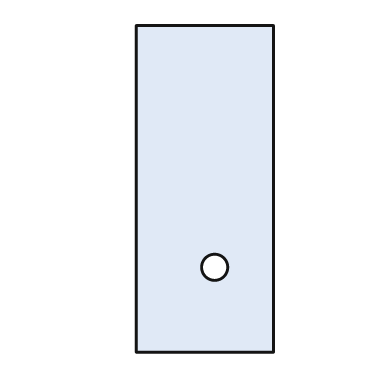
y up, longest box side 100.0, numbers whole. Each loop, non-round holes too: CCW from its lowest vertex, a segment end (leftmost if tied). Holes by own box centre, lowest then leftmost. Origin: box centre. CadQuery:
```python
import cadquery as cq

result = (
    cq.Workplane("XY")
    .moveTo(-21.0, -50.0)
    .lineTo(21.0, -50.0)
    .lineTo(21.0, 50.0)
    .lineTo(-21.0, 50.0)
    .close()
    .moveTo(3.0, -24.0)
    .circle(4.0)
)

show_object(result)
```